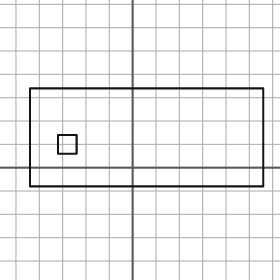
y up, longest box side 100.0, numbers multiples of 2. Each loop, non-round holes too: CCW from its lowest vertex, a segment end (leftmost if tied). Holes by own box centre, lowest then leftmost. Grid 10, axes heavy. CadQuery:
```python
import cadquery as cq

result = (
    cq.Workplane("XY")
    .moveTo(-44.0, -8.0)
    .lineTo(56.0, -8.0)
    .lineTo(56.0, 34.0)
    .lineTo(-44.0, 34.0)
    .close()
    .moveTo(-32.0, 6.0)
    .lineTo(-24.0, 6.0)
    .lineTo(-24.0, 14.0)
    .lineTo(-32.0, 14.0)
    .close()
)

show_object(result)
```